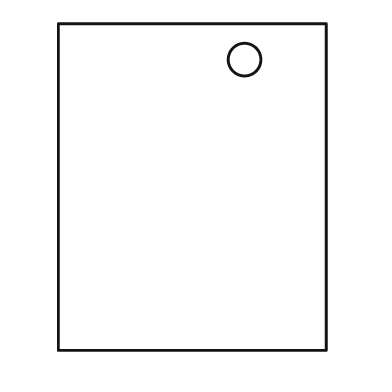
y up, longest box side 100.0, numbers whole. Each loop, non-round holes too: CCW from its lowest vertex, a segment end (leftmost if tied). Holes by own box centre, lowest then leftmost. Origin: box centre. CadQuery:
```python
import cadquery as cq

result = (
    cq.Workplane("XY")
    .moveTo(-41.0, -50.0)
    .lineTo(41.0, -50.0)
    .lineTo(41.0, 50.0)
    .lineTo(-41.0, 50.0)
    .close()
    .moveTo(16.0, 39.0)
    .circle(5.0)
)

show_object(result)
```